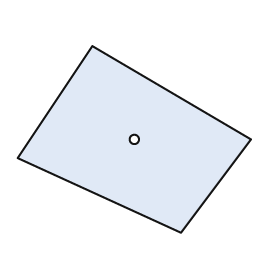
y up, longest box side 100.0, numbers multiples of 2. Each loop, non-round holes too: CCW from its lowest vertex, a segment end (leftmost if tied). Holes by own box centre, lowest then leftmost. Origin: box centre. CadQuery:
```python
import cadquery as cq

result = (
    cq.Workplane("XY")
    .moveTo(20.0, -40.0)
    .lineTo(50.0, 0.0)
    .lineTo(-18.0, 40.0)
    .lineTo(-50.0, -8.0)
    .close()
    .moveTo(0.0, 0.0)
    .circle(2.0)
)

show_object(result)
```